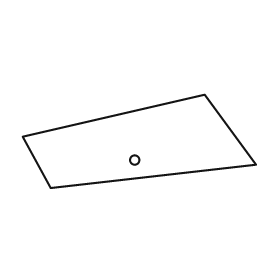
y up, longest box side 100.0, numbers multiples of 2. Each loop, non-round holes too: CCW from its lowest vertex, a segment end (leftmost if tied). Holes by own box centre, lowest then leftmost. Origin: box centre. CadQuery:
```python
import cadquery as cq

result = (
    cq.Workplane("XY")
    .moveTo(-38.0, -20.0)
    .lineTo(50.0, -10.0)
    .lineTo(28.0, 20.0)
    .lineTo(-50.0, 2.0)
    .close()
    .moveTo(-2.0, -8.0)
    .circle(2.0)
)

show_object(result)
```